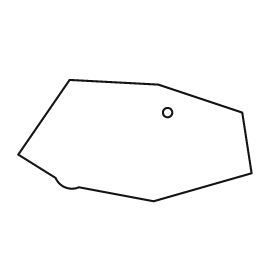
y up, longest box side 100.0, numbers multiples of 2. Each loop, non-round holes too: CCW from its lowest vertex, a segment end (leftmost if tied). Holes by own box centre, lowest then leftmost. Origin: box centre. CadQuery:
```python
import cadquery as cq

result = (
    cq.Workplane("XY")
    .moveTo(8.0, -26.0)
    .lineTo(50.0, -14.0)
    .lineTo(46.0, 12.0)
    .lineTo(10.0, 24.0)
    .lineTo(-28.0, 26.0)
    .lineTo(-50.0, -6.0)
    .lineTo(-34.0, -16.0)
    .threePointArc((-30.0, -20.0), (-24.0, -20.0))
    .close()
    .moveTo(14.0, 12.0)
    .circle(2.0)
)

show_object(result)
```